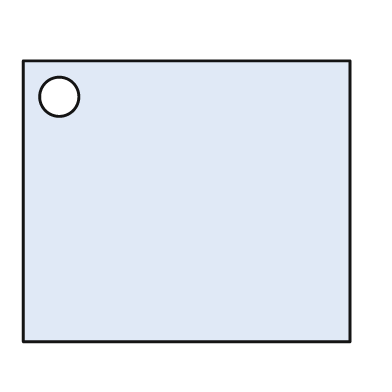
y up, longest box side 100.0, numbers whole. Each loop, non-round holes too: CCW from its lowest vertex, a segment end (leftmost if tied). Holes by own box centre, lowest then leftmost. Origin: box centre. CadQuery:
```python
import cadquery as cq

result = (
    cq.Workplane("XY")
    .moveTo(-50.0, -43.0)
    .lineTo(50.0, -43.0)
    .lineTo(50.0, 43.0)
    .lineTo(-50.0, 43.0)
    .close()
    .moveTo(-39.0, 32.0)
    .circle(6.0)
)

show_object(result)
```